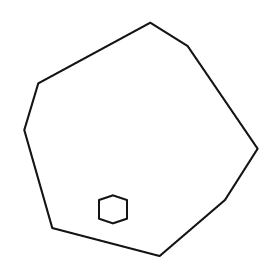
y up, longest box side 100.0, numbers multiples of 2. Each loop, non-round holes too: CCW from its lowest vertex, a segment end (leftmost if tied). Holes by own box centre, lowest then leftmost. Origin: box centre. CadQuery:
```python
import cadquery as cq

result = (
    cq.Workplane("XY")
    .moveTo(8.0, -50.0)
    .lineTo(36.0, -26.0)
    .lineTo(50.0, -4.0)
    .lineTo(20.0, 40.0)
    .lineTo(4.0, 50.0)
    .lineTo(-44.0, 24.0)
    .lineTo(-50.0, 4.0)
    .lineTo(-38.0, -38.0)
    .close()
    .moveTo(-12.0, -36.0)
    .lineTo(-6.0, -34.0)
    .lineTo(-6.0, -26.0)
    .lineTo(-12.0, -24.0)
    .lineTo(-18.0, -26.0)
    .lineTo(-18.0, -34.0)
    .close()
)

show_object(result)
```